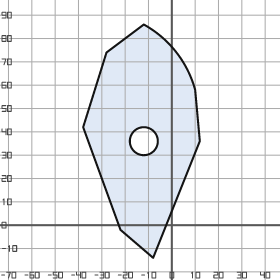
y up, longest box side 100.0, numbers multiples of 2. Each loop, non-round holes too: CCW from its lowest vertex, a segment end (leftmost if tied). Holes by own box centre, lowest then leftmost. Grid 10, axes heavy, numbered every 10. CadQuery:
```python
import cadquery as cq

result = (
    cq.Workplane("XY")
    .moveTo(-8.0, -14.0)
    .lineTo(12.0, 36.0)
    .lineTo(10.0, 58.0)
    .threePointArc((2.0, 74.0), (-12.0, 86.0))
    .lineTo(-28.0, 74.0)
    .lineTo(-38.0, 42.0)
    .lineTo(-22.0, -2.0)
    .close()
    .moveTo(-12.0, 36.0)
    .circle(6.0)
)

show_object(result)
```